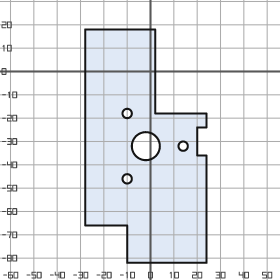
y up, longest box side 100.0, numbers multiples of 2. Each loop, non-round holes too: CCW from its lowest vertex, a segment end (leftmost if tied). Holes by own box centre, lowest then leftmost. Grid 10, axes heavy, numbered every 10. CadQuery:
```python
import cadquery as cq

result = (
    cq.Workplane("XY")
    .moveTo(-10.0, -82.0)
    .lineTo(24.0, -82.0)
    .lineTo(24.0, -36.0)
    .lineTo(20.0, -36.0)
    .lineTo(20.0, -24.0)
    .lineTo(24.0, -24.0)
    .lineTo(24.0, -18.0)
    .lineTo(2.0, -18.0)
    .lineTo(2.0, 18.0)
    .lineTo(-28.0, 18.0)
    .lineTo(-28.0, -66.0)
    .lineTo(-10.0, -66.0)
    .close()
    .moveTo(-10.0, -46.0)
    .circle(2.0)
    .moveTo(-2.0, -32.0)
    .circle(6.0)
    .moveTo(14.0, -32.0)
    .circle(2.0)
    .moveTo(-10.0, -18.0)
    .circle(2.0)
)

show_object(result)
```